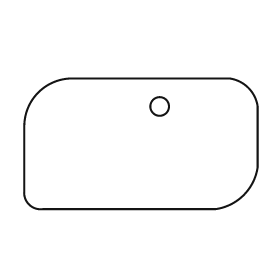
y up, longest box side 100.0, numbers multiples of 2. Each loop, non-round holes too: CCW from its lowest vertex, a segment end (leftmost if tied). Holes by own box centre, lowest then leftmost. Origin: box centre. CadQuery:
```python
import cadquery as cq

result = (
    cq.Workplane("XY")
    .moveTo(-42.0, -28.0)
    .lineTo(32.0, -28.0)
    .threePointArc((44.0, -22.0), (50.0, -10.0))
    .lineTo(50.0, 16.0)
    .threePointArc((46.0, 24.0), (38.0, 28.0))
    .lineTo(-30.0, 28.0)
    .threePointArc((-44.0, 22.0), (-50.0, 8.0))
    .lineTo(-50.0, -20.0)
    .threePointArc((-48.0, -26.0), (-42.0, -28.0))
    .close()
    .moveTo(8.0, 16.0)
    .circle(4.0)
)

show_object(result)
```